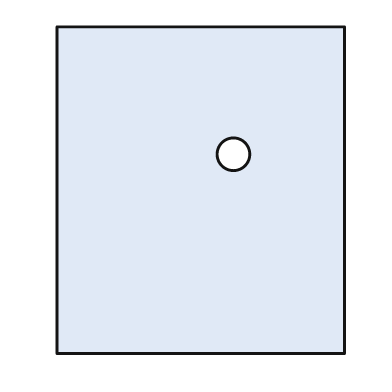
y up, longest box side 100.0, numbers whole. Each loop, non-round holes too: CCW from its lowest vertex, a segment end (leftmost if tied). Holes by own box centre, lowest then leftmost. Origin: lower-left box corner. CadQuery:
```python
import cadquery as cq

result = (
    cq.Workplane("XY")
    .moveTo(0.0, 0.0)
    .lineTo(88.0, 0.0)
    .lineTo(88.0, 100.0)
    .lineTo(0.0, 100.0)
    .close()
    .moveTo(54.0, 61.0)
    .circle(5.0)
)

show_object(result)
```